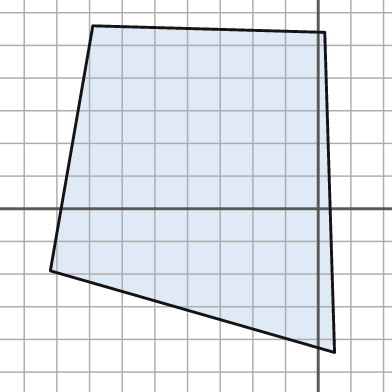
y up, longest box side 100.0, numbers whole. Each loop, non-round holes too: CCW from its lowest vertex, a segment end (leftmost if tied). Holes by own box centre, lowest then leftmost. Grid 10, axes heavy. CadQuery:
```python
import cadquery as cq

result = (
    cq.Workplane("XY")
    .moveTo(5.0, -44.0)
    .lineTo(2.0, 54.0)
    .lineTo(-69.0, 56.0)
    .lineTo(-82.0, -19.0)
    .close()
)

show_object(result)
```